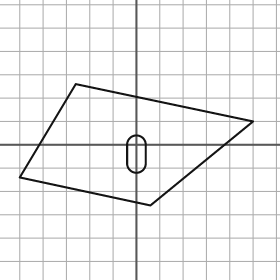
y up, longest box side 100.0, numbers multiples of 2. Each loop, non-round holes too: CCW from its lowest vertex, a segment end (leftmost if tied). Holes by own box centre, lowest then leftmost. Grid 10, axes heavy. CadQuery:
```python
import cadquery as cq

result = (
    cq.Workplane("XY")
    .moveTo(6.0, -26.0)
    .lineTo(50.0, 10.0)
    .lineTo(-26.0, 26.0)
    .lineTo(-50.0, -14.0)
    .close()
    .moveTo(-4.0, -8.0)
    .threePointArc((0.0, -12.0), (4.0, -8.0))
    .lineTo(4.0, 0.0)
    .threePointArc((0.0, 4.0), (-4.0, 0.0))
    .close()
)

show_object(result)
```